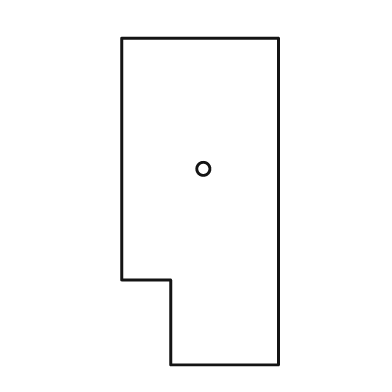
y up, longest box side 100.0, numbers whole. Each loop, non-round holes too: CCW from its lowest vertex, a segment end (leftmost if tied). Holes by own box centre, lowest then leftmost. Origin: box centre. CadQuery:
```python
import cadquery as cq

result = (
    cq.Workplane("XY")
    .moveTo(-9.0, -50.0)
    .lineTo(24.0, -50.0)
    .lineTo(24.0, 50.0)
    .lineTo(-24.0, 50.0)
    .lineTo(-24.0, -24.0)
    .lineTo(-9.0, -24.0)
    .close()
    .moveTo(1.0, 10.0)
    .circle(2.0)
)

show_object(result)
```